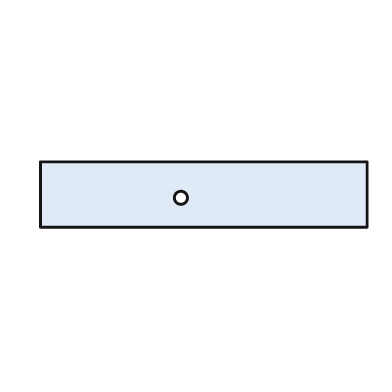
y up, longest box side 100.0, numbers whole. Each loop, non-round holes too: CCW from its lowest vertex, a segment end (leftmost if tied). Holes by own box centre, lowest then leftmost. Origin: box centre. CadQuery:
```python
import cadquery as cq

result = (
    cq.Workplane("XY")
    .moveTo(-50.0, -10.0)
    .lineTo(50.0, -10.0)
    .lineTo(50.0, 10.0)
    .lineTo(-50.0, 10.0)
    .close()
    .moveTo(-7.0, -1.0)
    .circle(2.0)
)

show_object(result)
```